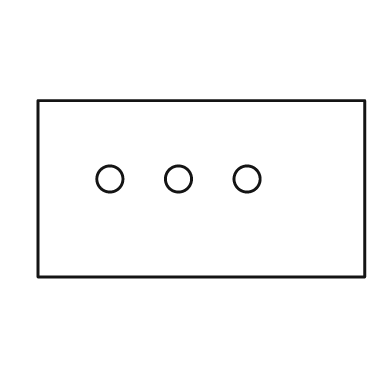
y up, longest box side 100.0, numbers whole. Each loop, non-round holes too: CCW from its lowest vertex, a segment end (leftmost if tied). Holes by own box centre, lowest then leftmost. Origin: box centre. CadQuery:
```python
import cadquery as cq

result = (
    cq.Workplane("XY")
    .moveTo(-50.0, -27.0)
    .lineTo(50.0, -27.0)
    .lineTo(50.0, 27.0)
    .lineTo(-50.0, 27.0)
    .close()
    .moveTo(-28.0, 3.0)
    .circle(4.0)
    .moveTo(-7.0, 3.0)
    .circle(4.0)
    .moveTo(14.0, 3.0)
    .circle(4.0)
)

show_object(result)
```